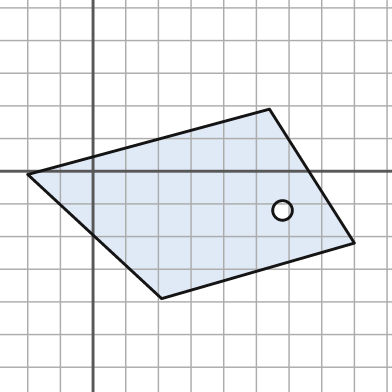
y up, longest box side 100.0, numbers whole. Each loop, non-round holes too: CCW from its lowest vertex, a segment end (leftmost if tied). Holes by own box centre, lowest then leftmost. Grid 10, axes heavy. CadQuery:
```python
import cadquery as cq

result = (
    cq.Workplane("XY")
    .moveTo(21.0, -39.0)
    .lineTo(80.0, -22.0)
    .lineTo(54.0, 19.0)
    .lineTo(-20.0, -1.0)
    .close()
    .moveTo(58.0, -12.0)
    .circle(3.0)
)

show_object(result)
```